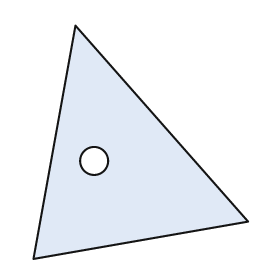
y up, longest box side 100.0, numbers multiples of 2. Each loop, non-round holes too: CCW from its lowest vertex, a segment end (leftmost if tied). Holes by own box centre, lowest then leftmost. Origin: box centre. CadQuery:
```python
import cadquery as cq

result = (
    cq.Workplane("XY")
    .moveTo(-46.0, -50.0)
    .lineTo(46.0, -34.0)
    .lineTo(-28.0, 50.0)
    .close()
    .moveTo(-20.0, -8.0)
    .circle(6.0)
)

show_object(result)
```